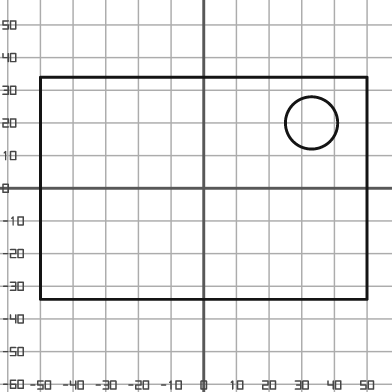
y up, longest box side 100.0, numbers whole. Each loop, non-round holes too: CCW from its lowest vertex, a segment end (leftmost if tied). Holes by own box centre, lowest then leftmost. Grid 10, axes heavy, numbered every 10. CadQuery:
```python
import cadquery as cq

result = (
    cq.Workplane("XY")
    .moveTo(-50.0, -34.0)
    .lineTo(50.0, -34.0)
    .lineTo(50.0, 34.0)
    .lineTo(-50.0, 34.0)
    .close()
    .moveTo(33.0, 20.0)
    .circle(8.0)
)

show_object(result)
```